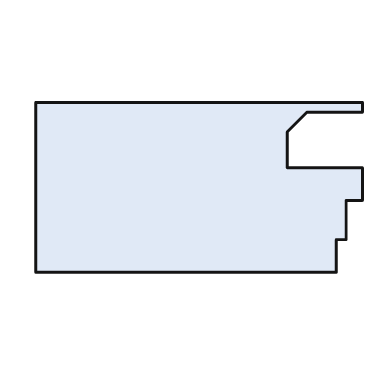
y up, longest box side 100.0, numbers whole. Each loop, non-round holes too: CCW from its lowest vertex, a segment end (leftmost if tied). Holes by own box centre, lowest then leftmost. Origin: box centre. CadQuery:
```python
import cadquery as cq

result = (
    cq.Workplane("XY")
    .moveTo(-50.0, -26.0)
    .lineTo(42.0, -26.0)
    .lineTo(42.0, -16.0)
    .lineTo(45.0, -16.0)
    .lineTo(45.0, -4.0)
    .lineTo(50.0, -4.0)
    .lineTo(50.0, 6.0)
    .lineTo(27.0, 6.0)
    .lineTo(27.0, 17.0)
    .lineTo(33.0, 23.0)
    .lineTo(50.0, 23.0)
    .lineTo(50.0, 26.0)
    .lineTo(-50.0, 26.0)
    .close()
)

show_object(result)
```